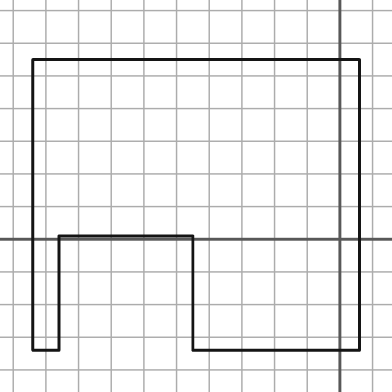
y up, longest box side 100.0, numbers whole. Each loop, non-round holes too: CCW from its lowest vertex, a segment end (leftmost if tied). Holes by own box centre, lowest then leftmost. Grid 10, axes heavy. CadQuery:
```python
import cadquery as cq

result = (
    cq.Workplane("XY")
    .moveTo(-94.0, -34.0)
    .lineTo(-86.0, -34.0)
    .lineTo(-86.0, 1.0)
    .lineTo(-45.0, 1.0)
    .lineTo(-45.0, -34.0)
    .lineTo(6.0, -34.0)
    .lineTo(6.0, 55.0)
    .lineTo(-94.0, 55.0)
    .close()
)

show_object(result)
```